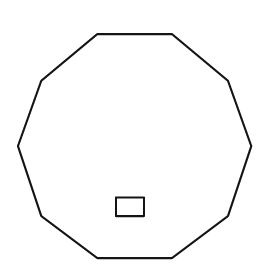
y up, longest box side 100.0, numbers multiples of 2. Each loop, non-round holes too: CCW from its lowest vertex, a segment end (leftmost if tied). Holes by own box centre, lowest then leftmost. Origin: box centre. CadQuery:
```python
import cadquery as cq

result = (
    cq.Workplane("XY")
    .moveTo(-16.0, -48.0)
    .lineTo(16.0, -48.0)
    .lineTo(40.0, -30.0)
    .lineTo(50.0, 0.0)
    .lineTo(40.0, 28.0)
    .lineTo(16.0, 48.0)
    .lineTo(-16.0, 48.0)
    .lineTo(-40.0, 28.0)
    .lineTo(-50.0, 0.0)
    .lineTo(-40.0, -30.0)
    .close()
    .moveTo(-8.0, -30.0)
    .lineTo(4.0, -30.0)
    .lineTo(4.0, -22.0)
    .lineTo(-8.0, -22.0)
    .close()
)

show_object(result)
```